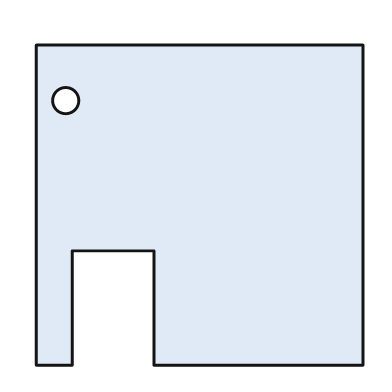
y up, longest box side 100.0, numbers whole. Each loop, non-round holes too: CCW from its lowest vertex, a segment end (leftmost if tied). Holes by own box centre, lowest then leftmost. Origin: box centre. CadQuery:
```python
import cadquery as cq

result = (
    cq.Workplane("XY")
    .moveTo(-50.0, -49.0)
    .lineTo(-39.0, -49.0)
    .lineTo(-39.0, -14.0)
    .lineTo(-14.0, -14.0)
    .lineTo(-14.0, -49.0)
    .lineTo(50.0, -49.0)
    .lineTo(50.0, 49.0)
    .lineTo(-50.0, 49.0)
    .close()
    .moveTo(-41.0, 32.0)
    .circle(4.0)
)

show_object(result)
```